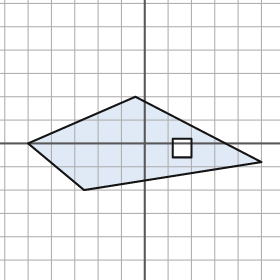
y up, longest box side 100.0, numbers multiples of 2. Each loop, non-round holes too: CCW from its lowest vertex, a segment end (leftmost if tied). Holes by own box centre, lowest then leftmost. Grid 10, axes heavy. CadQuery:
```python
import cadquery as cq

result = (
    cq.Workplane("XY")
    .moveTo(-26.0, -20.0)
    .lineTo(50.0, -8.0)
    .lineTo(-4.0, 20.0)
    .lineTo(-50.0, 0.0)
    .close()
    .moveTo(12.0, -6.0)
    .lineTo(20.0, -6.0)
    .lineTo(20.0, 2.0)
    .lineTo(12.0, 2.0)
    .close()
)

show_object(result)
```